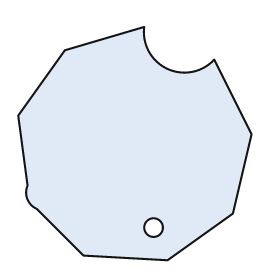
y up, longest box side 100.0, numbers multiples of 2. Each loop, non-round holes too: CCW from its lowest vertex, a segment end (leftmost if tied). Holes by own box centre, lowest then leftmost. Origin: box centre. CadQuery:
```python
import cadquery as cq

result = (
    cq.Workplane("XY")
    .moveTo(14.0, -50.0)
    .lineTo(42.0, -30.0)
    .lineTo(50.0, 4.0)
    .lineTo(34.0, 36.0)
    .threePointArc((14.0, 32.0), (4.0, 50.0))
    .lineTo(-30.0, 40.0)
    .lineTo(-50.0, 12.0)
    .lineTo(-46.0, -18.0)
    .threePointArc((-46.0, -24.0), (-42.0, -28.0))
    .lineTo(-22.0, -48.0)
    .close()
    .moveTo(8.0, -36.0)
    .circle(4.0)
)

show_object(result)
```